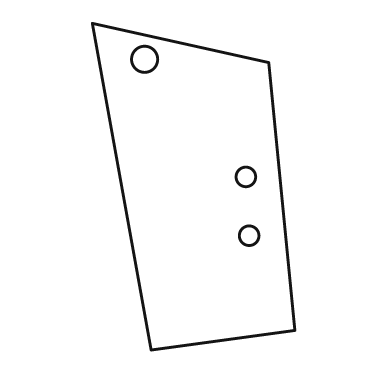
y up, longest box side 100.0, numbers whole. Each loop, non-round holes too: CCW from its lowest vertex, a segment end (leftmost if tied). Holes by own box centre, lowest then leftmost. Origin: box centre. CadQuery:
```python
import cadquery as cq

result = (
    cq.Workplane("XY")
    .moveTo(-13.0, -50.0)
    .lineTo(31.0, -44.0)
    .lineTo(23.0, 38.0)
    .lineTo(-31.0, 50.0)
    .close()
    .moveTo(17.0, -15.0)
    .circle(3.0)
    .moveTo(16.0, 3.0)
    .circle(3.0)
    .moveTo(-15.0, 39.0)
    .circle(4.0)
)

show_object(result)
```